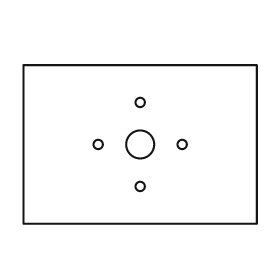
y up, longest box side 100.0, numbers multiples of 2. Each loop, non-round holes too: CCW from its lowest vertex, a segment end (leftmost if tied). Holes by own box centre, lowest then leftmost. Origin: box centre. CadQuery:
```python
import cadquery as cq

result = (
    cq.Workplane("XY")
    .moveTo(-50.0, -34.0)
    .lineTo(50.0, -34.0)
    .lineTo(50.0, 34.0)
    .lineTo(-50.0, 34.0)
    .close()
    .moveTo(0.0, -18.0)
    .circle(2.0)
    .moveTo(-18.0, 0.0)
    .circle(2.0)
    .moveTo(0.0, 0.0)
    .circle(6.0)
    .moveTo(18.0, 0.0)
    .circle(2.0)
    .moveTo(0.0, 18.0)
    .circle(2.0)
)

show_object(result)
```